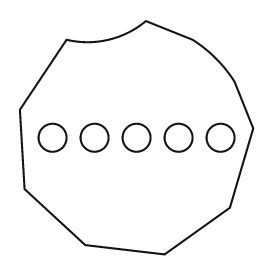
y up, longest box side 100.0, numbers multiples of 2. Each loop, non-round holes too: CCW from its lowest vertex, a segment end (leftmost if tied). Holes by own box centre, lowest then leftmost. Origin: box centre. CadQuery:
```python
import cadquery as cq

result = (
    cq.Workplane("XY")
    .moveTo(12.0, -50.0)
    .lineTo(40.0, -30.0)
    .lineTo(50.0, 4.0)
    .lineTo(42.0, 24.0)
    .threePointArc((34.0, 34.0), (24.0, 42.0))
    .lineTo(4.0, 50.0)
    .threePointArc((-12.0, 42.0), (-30.0, 42.0))
    .lineTo(-50.0, 12.0)
    .lineTo(-48.0, -22.0)
    .lineTo(-22.0, -46.0)
    .close()
    .moveTo(-36.0, 0.0)
    .circle(6.0)
    .moveTo(-18.0, 0.0)
    .circle(6.0)
    .moveTo(0.0, 0.0)
    .circle(6.0)
    .moveTo(18.0, 0.0)
    .circle(6.0)
    .moveTo(36.0, 0.0)
    .circle(6.0)
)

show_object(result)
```